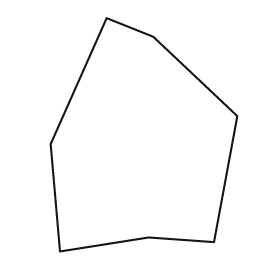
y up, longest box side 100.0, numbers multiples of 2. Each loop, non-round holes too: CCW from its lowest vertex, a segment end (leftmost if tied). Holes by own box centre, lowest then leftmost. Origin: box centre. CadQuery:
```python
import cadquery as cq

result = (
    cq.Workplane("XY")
    .moveTo(-36.0, -50.0)
    .lineTo(2.0, -44.0)
    .lineTo(30.0, -46.0)
    .lineTo(40.0, 8.0)
    .lineTo(4.0, 42.0)
    .lineTo(-16.0, 50.0)
    .lineTo(-40.0, -4.0)
    .close()
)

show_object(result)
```